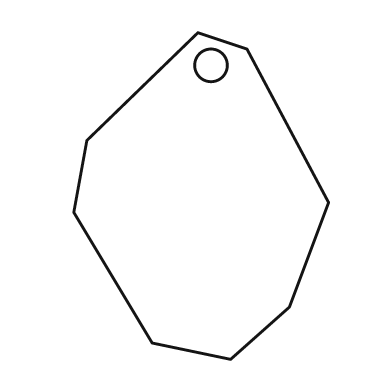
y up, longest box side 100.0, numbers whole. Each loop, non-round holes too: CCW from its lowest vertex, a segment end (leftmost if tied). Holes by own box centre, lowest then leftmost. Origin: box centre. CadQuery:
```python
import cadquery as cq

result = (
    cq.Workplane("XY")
    .moveTo(9.0, -50.0)
    .lineTo(27.0, -34.0)
    .lineTo(39.0, -2.0)
    .lineTo(14.0, 45.0)
    .lineTo(-1.0, 50.0)
    .lineTo(-35.0, 17.0)
    .lineTo(-39.0, -5.0)
    .lineTo(-15.0, -45.0)
    .close()
    .moveTo(3.0, 40.0)
    .circle(5.0)
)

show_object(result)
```